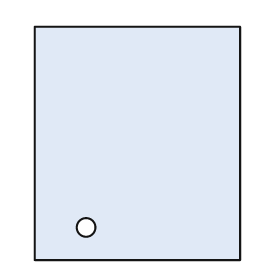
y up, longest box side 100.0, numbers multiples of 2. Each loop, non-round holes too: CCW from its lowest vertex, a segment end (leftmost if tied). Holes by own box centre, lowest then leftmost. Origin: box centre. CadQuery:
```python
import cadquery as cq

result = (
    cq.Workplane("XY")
    .moveTo(-44.0, -50.0)
    .lineTo(44.0, -50.0)
    .lineTo(44.0, 50.0)
    .lineTo(-44.0, 50.0)
    .close()
    .moveTo(-22.0, -36.0)
    .circle(4.0)
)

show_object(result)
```